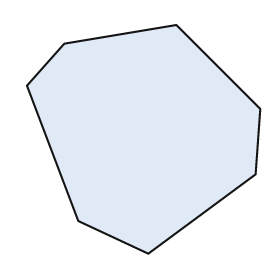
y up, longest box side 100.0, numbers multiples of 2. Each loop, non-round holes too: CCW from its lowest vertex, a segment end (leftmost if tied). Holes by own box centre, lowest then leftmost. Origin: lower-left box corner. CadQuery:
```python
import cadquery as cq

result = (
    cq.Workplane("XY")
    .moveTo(52.0, 0.0)
    .lineTo(98.0, 34.0)
    .lineTo(100.0, 62.0)
    .lineTo(64.0, 98.0)
    .lineTo(16.0, 90.0)
    .lineTo(0.0, 72.0)
    .lineTo(22.0, 14.0)
    .close()
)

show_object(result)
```